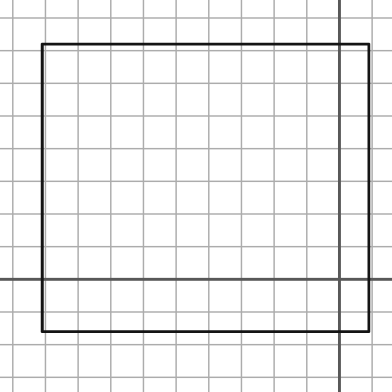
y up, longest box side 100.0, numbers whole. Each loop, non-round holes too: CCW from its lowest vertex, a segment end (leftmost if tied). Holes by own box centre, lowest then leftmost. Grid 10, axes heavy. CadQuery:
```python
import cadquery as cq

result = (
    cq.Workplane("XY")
    .moveTo(-91.0, -16.0)
    .lineTo(9.0, -16.0)
    .lineTo(9.0, 72.0)
    .lineTo(-91.0, 72.0)
    .close()
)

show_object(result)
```